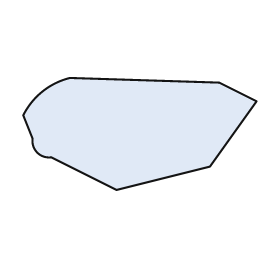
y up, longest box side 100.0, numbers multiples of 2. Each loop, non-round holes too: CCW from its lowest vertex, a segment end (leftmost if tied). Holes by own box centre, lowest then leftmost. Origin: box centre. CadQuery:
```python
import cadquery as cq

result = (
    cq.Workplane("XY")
    .moveTo(-10.0, -24.0)
    .lineTo(30.0, -14.0)
    .lineTo(50.0, 14.0)
    .lineTo(34.0, 22.0)
    .lineTo(-30.0, 24.0)
    .threePointArc((-42.0, 18.0), (-50.0, 8.0))
    .lineTo(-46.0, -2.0)
    .threePointArc((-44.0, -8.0), (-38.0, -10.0))
    .close()
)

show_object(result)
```